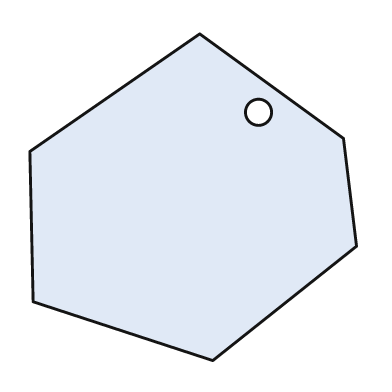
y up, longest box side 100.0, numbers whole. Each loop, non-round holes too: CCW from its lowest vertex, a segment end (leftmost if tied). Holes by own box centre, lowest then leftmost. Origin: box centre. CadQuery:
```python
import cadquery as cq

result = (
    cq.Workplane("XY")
    .moveTo(6.0, -50.0)
    .lineTo(50.0, -15.0)
    .lineTo(46.0, 18.0)
    .lineTo(2.0, 50.0)
    .lineTo(-50.0, 14.0)
    .lineTo(-49.0, -32.0)
    .close()
    .moveTo(20.0, 26.0)
    .circle(4.0)
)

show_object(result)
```